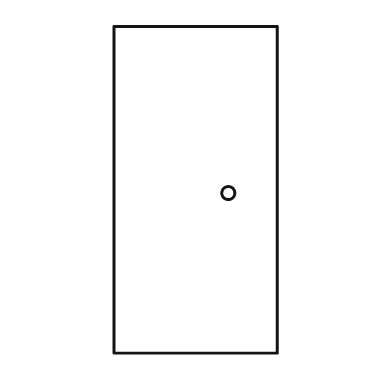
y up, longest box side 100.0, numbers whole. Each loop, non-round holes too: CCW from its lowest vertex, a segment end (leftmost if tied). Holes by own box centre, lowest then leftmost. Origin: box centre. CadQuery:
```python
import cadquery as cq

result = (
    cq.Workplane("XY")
    .moveTo(-25.0, -50.0)
    .lineTo(25.0, -50.0)
    .lineTo(25.0, 50.0)
    .lineTo(-25.0, 50.0)
    .close()
    .moveTo(10.0, -1.0)
    .circle(2.0)
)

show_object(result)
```